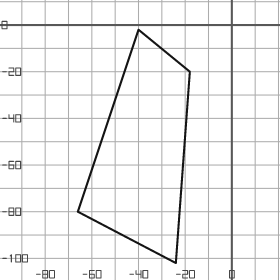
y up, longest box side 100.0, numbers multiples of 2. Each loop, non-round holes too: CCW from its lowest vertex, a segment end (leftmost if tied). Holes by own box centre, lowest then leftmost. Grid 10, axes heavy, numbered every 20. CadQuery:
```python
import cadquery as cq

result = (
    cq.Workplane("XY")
    .moveTo(-24.0, -102.0)
    .lineTo(-18.0, -20.0)
    .lineTo(-40.0, -2.0)
    .lineTo(-66.0, -80.0)
    .close()
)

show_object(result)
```